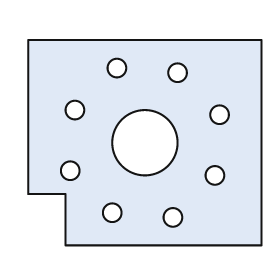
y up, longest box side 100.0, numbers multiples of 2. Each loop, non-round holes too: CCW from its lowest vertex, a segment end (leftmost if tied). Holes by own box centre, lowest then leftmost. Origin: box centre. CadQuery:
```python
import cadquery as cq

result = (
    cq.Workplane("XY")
    .moveTo(-34.0, -44.0)
    .lineTo(50.0, -44.0)
    .lineTo(50.0, 44.0)
    .lineTo(-50.0, 44.0)
    .lineTo(-50.0, -22.0)
    .lineTo(-34.0, -22.0)
    .close()
    .moveTo(12.0, -32.0)
    .circle(4.0)
    .moveTo(-14.0, -30.0)
    .circle(4.0)
    .moveTo(30.0, -14.0)
    .circle(4.0)
    .moveTo(-32.0, -12.0)
    .circle(4.0)
    .moveTo(0.0, 0.0)
    .circle(14.0)
    .moveTo(32.0, 12.0)
    .circle(4.0)
    .moveTo(-30.0, 14.0)
    .circle(4.0)
    .moveTo(14.0, 30.0)
    .circle(4.0)
    .moveTo(-12.0, 32.0)
    .circle(4.0)
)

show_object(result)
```